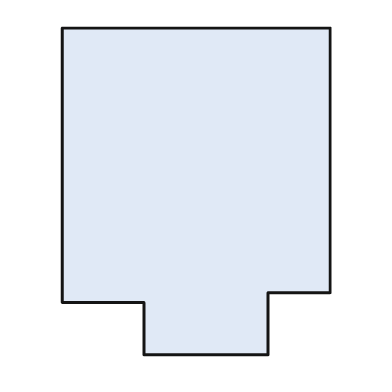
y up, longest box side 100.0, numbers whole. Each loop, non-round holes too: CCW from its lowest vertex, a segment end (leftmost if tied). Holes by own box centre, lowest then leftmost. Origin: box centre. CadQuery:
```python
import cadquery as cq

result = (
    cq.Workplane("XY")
    .moveTo(-16.0, -50.0)
    .lineTo(22.0, -50.0)
    .lineTo(22.0, -31.0)
    .lineTo(41.0, -31.0)
    .lineTo(41.0, 50.0)
    .lineTo(-41.0, 50.0)
    .lineTo(-41.0, -34.0)
    .lineTo(-16.0, -34.0)
    .close()
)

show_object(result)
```